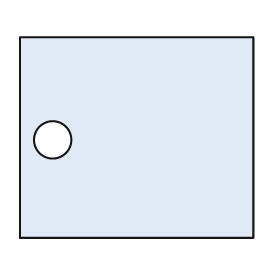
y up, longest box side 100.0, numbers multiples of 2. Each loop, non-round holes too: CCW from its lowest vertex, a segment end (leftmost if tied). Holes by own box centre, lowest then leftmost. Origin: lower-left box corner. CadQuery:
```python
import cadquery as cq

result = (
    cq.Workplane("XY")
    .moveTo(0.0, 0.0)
    .lineTo(100.0, 0.0)
    .lineTo(100.0, 86.0)
    .lineTo(0.0, 86.0)
    .close()
    .moveTo(14.0, 42.0)
    .circle(8.0)
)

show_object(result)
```